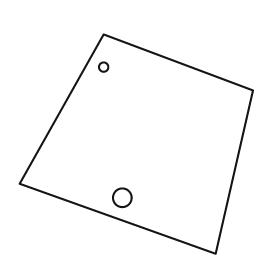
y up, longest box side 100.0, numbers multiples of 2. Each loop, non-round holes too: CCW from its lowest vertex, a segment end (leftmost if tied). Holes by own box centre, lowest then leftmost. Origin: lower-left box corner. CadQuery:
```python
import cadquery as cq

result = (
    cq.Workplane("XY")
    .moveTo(84.0, 0.0)
    .lineTo(100.0, 70.0)
    .lineTo(36.0, 94.0)
    .lineTo(0.0, 30.0)
    .close()
    .moveTo(44.0, 24.0)
    .circle(4.0)
    .moveTo(36.0, 80.0)
    .circle(2.0)
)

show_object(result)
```